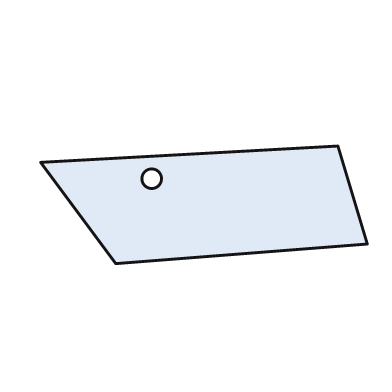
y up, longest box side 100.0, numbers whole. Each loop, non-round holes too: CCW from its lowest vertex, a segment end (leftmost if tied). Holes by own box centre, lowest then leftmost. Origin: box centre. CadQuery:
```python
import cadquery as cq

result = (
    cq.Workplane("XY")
    .moveTo(-27.0, -18.0)
    .lineTo(50.0, -12.0)
    .lineTo(41.0, 18.0)
    .lineTo(-50.0, 13.0)
    .close()
    .moveTo(-16.0, 8.0)
    .circle(3.0)
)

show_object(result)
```